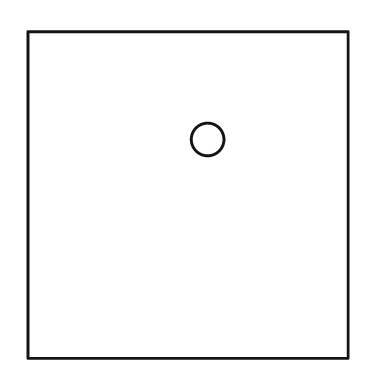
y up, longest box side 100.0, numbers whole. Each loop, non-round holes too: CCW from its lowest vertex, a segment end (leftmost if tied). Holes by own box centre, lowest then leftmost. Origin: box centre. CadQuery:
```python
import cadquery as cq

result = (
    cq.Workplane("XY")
    .moveTo(-49.0, -50.0)
    .lineTo(49.0, -50.0)
    .lineTo(49.0, 50.0)
    .lineTo(-49.0, 50.0)
    .close()
    .moveTo(6.0, 17.0)
    .circle(5.0)
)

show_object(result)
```